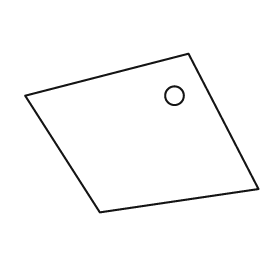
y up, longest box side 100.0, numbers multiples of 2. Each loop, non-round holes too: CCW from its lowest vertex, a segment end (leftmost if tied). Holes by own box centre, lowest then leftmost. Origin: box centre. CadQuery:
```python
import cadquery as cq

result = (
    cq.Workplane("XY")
    .moveTo(-18.0, -34.0)
    .lineTo(50.0, -24.0)
    .lineTo(20.0, 34.0)
    .lineTo(-50.0, 16.0)
    .close()
    .moveTo(14.0, 16.0)
    .circle(4.0)
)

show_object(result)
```